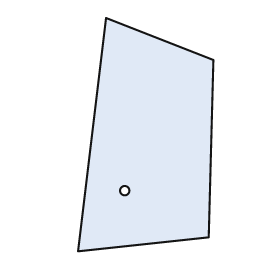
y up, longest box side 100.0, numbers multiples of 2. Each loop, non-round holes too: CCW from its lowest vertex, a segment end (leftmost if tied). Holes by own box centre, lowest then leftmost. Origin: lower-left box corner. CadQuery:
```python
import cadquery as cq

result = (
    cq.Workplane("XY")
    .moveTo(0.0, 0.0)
    .lineTo(56.0, 6.0)
    .lineTo(58.0, 82.0)
    .lineTo(12.0, 100.0)
    .close()
    .moveTo(20.0, 26.0)
    .circle(2.0)
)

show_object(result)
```